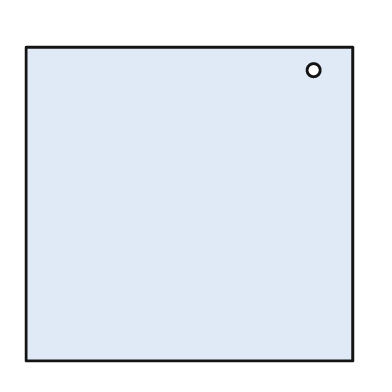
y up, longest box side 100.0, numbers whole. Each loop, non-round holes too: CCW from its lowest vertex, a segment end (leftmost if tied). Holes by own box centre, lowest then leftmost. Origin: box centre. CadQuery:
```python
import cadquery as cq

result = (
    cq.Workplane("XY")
    .moveTo(-50.0, -48.0)
    .lineTo(50.0, -48.0)
    .lineTo(50.0, 48.0)
    .lineTo(-50.0, 48.0)
    .close()
    .moveTo(38.0, 41.0)
    .circle(2.0)
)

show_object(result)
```